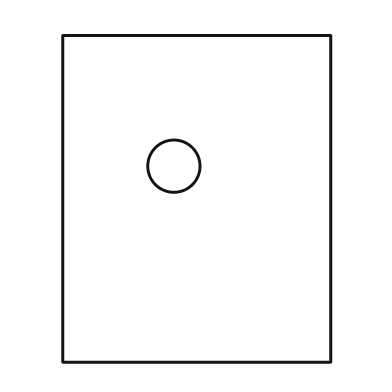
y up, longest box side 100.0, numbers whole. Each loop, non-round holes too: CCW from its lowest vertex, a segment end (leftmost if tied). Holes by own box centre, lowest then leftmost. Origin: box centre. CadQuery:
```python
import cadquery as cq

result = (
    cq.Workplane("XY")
    .moveTo(-41.0, -50.0)
    .lineTo(41.0, -50.0)
    .lineTo(41.0, 50.0)
    .lineTo(-41.0, 50.0)
    .close()
    .moveTo(-7.0, 10.0)
    .circle(8.0)
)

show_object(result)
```